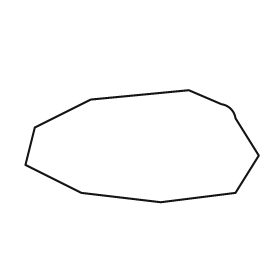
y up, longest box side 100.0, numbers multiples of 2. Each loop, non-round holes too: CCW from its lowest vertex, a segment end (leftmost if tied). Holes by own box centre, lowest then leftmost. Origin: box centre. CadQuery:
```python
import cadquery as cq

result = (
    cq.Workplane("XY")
    .moveTo(8.0, -24.0)
    .lineTo(40.0, -20.0)
    .lineTo(50.0, -4.0)
    .lineTo(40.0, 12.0)
    .threePointArc((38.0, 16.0), (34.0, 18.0))
    .lineTo(20.0, 24.0)
    .lineTo(-22.0, 20.0)
    .lineTo(-46.0, 8.0)
    .lineTo(-50.0, -8.0)
    .lineTo(-26.0, -20.0)
    .close()
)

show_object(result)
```